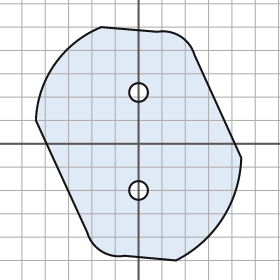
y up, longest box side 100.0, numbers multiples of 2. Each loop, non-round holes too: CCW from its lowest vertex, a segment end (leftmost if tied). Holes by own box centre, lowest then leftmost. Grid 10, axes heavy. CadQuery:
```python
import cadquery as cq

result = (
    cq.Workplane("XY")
    .moveTo(16.0, -50.0)
    .threePointArc((36.0, -32.0), (44.0, -6.0))
    .lineTo(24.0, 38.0)
    .threePointArc((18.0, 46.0), (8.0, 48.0))
    .lineTo(-16.0, 50.0)
    .threePointArc((-36.0, 34.0), (-44.0, 10.0))
    .lineTo(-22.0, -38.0)
    .threePointArc((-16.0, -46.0), (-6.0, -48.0))
    .close()
    .moveTo(0.0, -20.0)
    .circle(4.0)
    .moveTo(0.0, 22.0)
    .circle(4.0)
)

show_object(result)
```